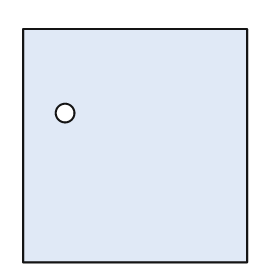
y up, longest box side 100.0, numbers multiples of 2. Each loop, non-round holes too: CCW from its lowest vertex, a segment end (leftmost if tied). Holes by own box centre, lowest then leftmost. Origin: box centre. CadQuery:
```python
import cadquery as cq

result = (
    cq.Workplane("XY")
    .moveTo(-48.0, -50.0)
    .lineTo(48.0, -50.0)
    .lineTo(48.0, 50.0)
    .lineTo(-48.0, 50.0)
    .close()
    .moveTo(-30.0, 14.0)
    .circle(4.0)
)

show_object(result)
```